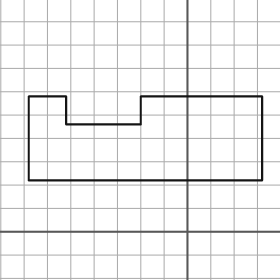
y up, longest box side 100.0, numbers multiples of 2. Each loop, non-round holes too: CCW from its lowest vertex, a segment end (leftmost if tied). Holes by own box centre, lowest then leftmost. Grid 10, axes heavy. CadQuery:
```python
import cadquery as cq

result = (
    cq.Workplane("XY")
    .moveTo(-68.0, 22.0)
    .lineTo(32.0, 22.0)
    .lineTo(32.0, 58.0)
    .lineTo(-20.0, 58.0)
    .lineTo(-20.0, 46.0)
    .lineTo(-52.0, 46.0)
    .lineTo(-52.0, 58.0)
    .lineTo(-68.0, 58.0)
    .close()
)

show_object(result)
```